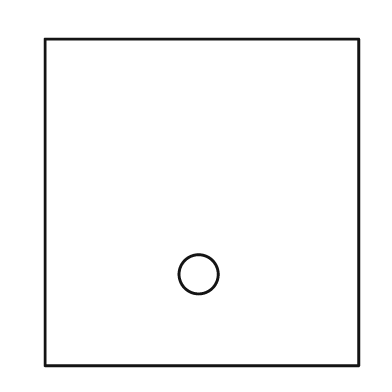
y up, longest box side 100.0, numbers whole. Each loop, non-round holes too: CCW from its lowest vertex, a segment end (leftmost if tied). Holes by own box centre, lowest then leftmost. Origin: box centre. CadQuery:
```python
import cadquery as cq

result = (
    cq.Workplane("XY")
    .moveTo(-48.0, -50.0)
    .lineTo(48.0, -50.0)
    .lineTo(48.0, 50.0)
    .lineTo(-48.0, 50.0)
    .close()
    .moveTo(-1.0, -22.0)
    .circle(6.0)
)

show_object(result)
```